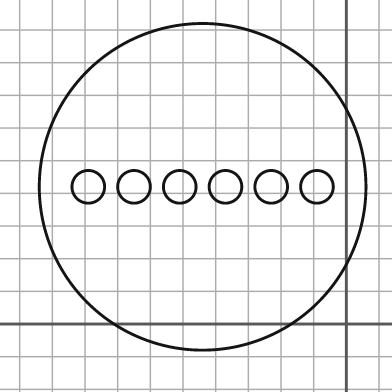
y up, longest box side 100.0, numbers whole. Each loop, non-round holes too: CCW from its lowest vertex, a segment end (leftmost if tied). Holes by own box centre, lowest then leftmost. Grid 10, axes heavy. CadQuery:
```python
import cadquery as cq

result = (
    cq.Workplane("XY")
    .moveTo(-44.0, 42.0)
    .circle(50.0)
    .moveTo(-79.0, 42.0)
    .circle(5.0)
    .moveTo(-65.0, 42.0)
    .circle(5.0)
    .moveTo(-51.0, 42.0)
    .circle(5.0)
    .moveTo(-37.0, 42.0)
    .circle(5.0)
    .moveTo(-23.0, 42.0)
    .circle(5.0)
    .moveTo(-9.0, 42.0)
    .circle(5.0)
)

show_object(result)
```